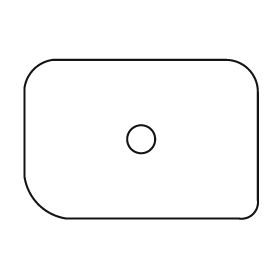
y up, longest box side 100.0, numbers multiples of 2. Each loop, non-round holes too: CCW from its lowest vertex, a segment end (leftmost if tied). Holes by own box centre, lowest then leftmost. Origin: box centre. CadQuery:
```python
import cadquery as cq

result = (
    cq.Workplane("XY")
    .moveTo(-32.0, -34.0)
    .lineTo(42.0, -34.0)
    .threePointArc((48.0, -32.0), (50.0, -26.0))
    .lineTo(50.0, 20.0)
    .threePointArc((46.0, 30.0), (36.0, 34.0))
    .lineTo(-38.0, 34.0)
    .threePointArc((-46.0, 30.0), (-50.0, 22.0))
    .lineTo(-50.0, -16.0)
    .threePointArc((-44.0, -28.0), (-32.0, -34.0))
    .close()
    .moveTo(0.0, 0.0)
    .circle(6.0)
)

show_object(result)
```